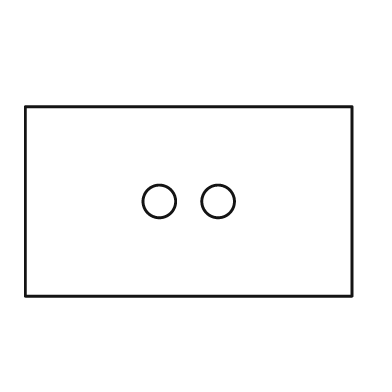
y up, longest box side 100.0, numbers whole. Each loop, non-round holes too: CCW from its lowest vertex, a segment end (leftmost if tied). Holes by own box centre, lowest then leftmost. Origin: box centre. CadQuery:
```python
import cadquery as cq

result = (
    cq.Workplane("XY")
    .moveTo(-50.0, -29.0)
    .lineTo(50.0, -29.0)
    .lineTo(50.0, 29.0)
    .lineTo(-50.0, 29.0)
    .close()
    .moveTo(-9.0, 0.0)
    .circle(5.0)
    .moveTo(9.0, 0.0)
    .circle(5.0)
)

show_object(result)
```